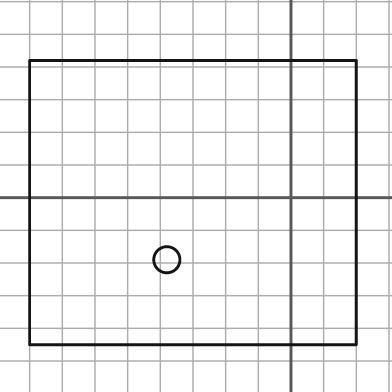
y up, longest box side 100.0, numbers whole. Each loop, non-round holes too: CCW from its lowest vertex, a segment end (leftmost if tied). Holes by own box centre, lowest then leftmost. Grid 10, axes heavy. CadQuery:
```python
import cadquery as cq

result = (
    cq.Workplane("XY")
    .moveTo(-80.0, -45.0)
    .lineTo(20.0, -45.0)
    .lineTo(20.0, 42.0)
    .lineTo(-80.0, 42.0)
    .close()
    .moveTo(-38.0, -19.0)
    .circle(4.0)
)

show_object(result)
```